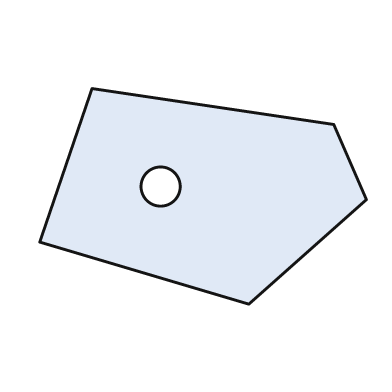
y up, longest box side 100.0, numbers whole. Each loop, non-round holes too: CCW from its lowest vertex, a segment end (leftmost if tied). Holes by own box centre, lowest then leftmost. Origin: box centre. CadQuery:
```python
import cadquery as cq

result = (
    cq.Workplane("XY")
    .moveTo(14.0, -33.0)
    .lineTo(50.0, -1.0)
    .lineTo(40.0, 22.0)
    .lineTo(-34.0, 33.0)
    .lineTo(-50.0, -14.0)
    .close()
    .moveTo(-13.0, 3.0)
    .circle(6.0)
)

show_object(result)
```